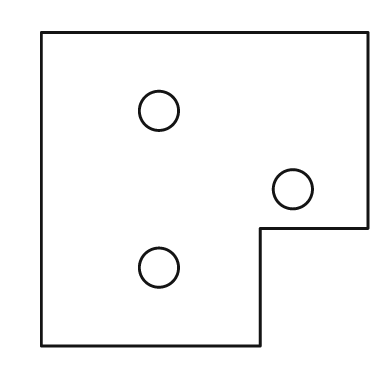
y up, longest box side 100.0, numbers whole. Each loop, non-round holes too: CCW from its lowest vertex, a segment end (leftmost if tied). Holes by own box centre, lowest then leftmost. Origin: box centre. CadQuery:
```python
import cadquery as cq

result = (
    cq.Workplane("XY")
    .moveTo(-50.0, -48.0)
    .lineTo(17.0, -48.0)
    .lineTo(17.0, -12.0)
    .lineTo(50.0, -12.0)
    .lineTo(50.0, 48.0)
    .lineTo(-50.0, 48.0)
    .close()
    .moveTo(-14.0, -24.0)
    .circle(6.0)
    .moveTo(27.0, 0.0)
    .circle(6.0)
    .moveTo(-14.0, 24.0)
    .circle(6.0)
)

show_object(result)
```